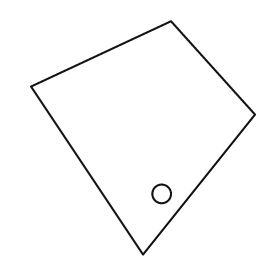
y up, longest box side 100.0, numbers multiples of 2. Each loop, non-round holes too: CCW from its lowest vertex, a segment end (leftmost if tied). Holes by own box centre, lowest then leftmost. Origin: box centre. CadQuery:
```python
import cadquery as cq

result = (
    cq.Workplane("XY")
    .moveTo(0.0, -50.0)
    .lineTo(48.0, 10.0)
    .lineTo(12.0, 50.0)
    .lineTo(-48.0, 22.0)
    .close()
    .moveTo(8.0, -24.0)
    .circle(4.0)
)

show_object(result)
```